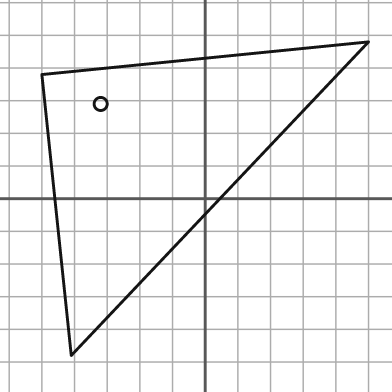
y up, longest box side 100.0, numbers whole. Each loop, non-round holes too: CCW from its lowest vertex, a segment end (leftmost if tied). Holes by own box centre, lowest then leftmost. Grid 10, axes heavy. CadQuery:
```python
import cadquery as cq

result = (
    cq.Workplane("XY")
    .moveTo(-41.0, -48.0)
    .lineTo(50.0, 48.0)
    .lineTo(-50.0, 38.0)
    .close()
    .moveTo(-32.0, 29.0)
    .circle(2.0)
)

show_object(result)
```